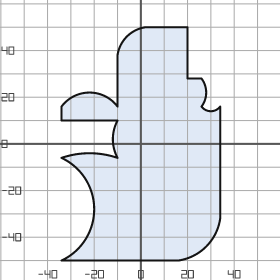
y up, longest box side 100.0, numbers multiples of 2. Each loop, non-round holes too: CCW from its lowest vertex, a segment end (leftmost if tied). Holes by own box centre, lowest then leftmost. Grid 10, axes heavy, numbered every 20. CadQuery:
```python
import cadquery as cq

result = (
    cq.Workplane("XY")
    .moveTo(-34.0, -50.0)
    .lineTo(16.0, -50.0)
    .threePointArc((28.0, -44.0), (34.0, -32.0))
    .lineTo(34.0, 16.0)
    .threePointArc((30.0, 14.0), (26.0, 16.0))
    .threePointArc((28.0, 22.0), (26.0, 28.0))
    .lineTo(20.0, 28.0)
    .lineTo(20.0, 50.0)
    .lineTo(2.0, 50.0)
    .threePointArc((-6.0, 46.0), (-10.0, 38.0))
    .lineTo(-10.0, 16.0)
    .threePointArc((-22.0, 22.0), (-34.0, 16.0))
    .lineTo(-34.0, 10.0)
    .lineTo(-10.0, 10.0)
    .threePointArc((-12.0, 2.0), (-10.0, -6.0))
    .threePointArc((-22.0, -4.0), (-34.0, -6.0))
    .threePointArc((-20.0, -28.0), (-34.0, -50.0))
    .close()
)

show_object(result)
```